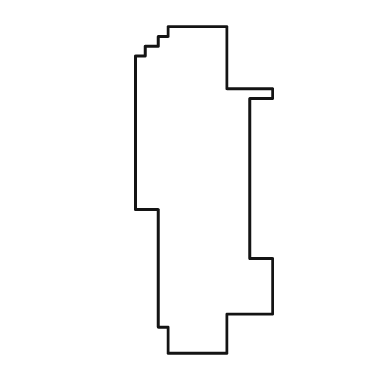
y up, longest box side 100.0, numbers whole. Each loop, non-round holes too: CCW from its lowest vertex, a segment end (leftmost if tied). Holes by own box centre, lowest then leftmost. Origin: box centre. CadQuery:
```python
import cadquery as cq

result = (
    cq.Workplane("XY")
    .moveTo(-11.0, -50.0)
    .lineTo(7.0, -50.0)
    .lineTo(7.0, -38.0)
    .lineTo(21.0, -38.0)
    .lineTo(21.0, -21.0)
    .lineTo(14.0, -21.0)
    .lineTo(14.0, 28.0)
    .lineTo(21.0, 28.0)
    .lineTo(21.0, 31.0)
    .lineTo(7.0, 31.0)
    .lineTo(7.0, 50.0)
    .lineTo(-11.0, 50.0)
    .lineTo(-11.0, 47.0)
    .lineTo(-14.0, 47.0)
    .lineTo(-14.0, 44.0)
    .lineTo(-18.0, 44.0)
    .lineTo(-18.0, 41.0)
    .lineTo(-21.0, 41.0)
    .lineTo(-21.0, -6.0)
    .lineTo(-14.0, -6.0)
    .lineTo(-14.0, -42.0)
    .lineTo(-11.0, -42.0)
    .close()
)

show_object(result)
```